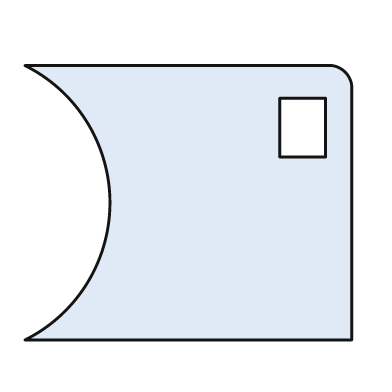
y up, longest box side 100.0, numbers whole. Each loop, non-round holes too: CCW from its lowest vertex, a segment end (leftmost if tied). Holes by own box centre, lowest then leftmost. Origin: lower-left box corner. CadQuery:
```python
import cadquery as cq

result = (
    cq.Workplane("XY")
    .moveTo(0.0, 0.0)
    .lineTo(100.0, 0.0)
    .lineTo(100.0, 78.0)
    .threePointArc((98.0, 82.0), (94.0, 84.0))
    .lineTo(0.0, 84.0)
    .threePointArc((26.0, 42.0), (0.0, 0.0))
    .close()
    .moveTo(78.0, 56.0)
    .lineTo(92.0, 56.0)
    .lineTo(92.0, 74.0)
    .lineTo(78.0, 74.0)
    .close()
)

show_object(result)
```